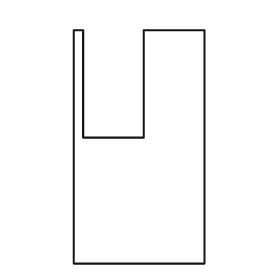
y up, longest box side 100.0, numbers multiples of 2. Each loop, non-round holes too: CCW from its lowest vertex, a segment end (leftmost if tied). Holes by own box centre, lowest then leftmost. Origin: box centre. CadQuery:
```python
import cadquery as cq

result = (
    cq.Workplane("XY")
    .moveTo(-28.0, -50.0)
    .lineTo(28.0, -50.0)
    .lineTo(28.0, 50.0)
    .lineTo(2.0, 50.0)
    .lineTo(2.0, 4.0)
    .lineTo(-24.0, 4.0)
    .lineTo(-24.0, 50.0)
    .lineTo(-28.0, 50.0)
    .close()
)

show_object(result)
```